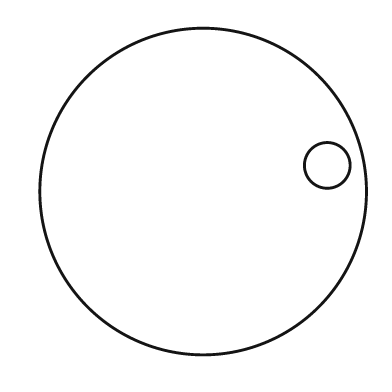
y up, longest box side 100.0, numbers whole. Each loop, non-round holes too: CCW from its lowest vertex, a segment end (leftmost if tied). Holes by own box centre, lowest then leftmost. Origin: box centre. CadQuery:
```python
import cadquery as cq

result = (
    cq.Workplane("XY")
    .moveTo(0.0, 0.0)
    .circle(50.0)
    .moveTo(38.0, 8.0)
    .circle(7.0)
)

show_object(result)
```